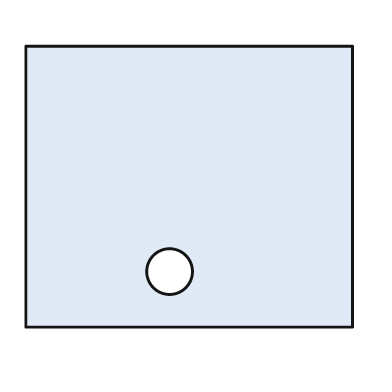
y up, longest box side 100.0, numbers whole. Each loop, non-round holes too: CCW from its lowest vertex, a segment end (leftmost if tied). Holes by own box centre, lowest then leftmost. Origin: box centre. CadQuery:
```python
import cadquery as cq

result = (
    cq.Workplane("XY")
    .moveTo(-50.0, -43.0)
    .lineTo(50.0, -43.0)
    .lineTo(50.0, 43.0)
    .lineTo(-50.0, 43.0)
    .close()
    .moveTo(-6.0, -26.0)
    .circle(7.0)
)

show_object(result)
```